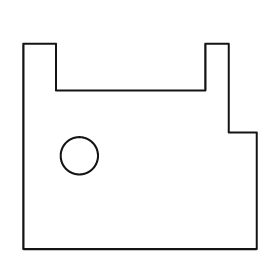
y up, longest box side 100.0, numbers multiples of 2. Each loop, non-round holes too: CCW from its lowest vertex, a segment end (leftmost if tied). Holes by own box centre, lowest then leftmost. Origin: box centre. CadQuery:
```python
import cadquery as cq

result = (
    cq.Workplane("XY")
    .moveTo(-50.0, -44.0)
    .lineTo(50.0, -44.0)
    .lineTo(50.0, 6.0)
    .lineTo(38.0, 6.0)
    .lineTo(38.0, 44.0)
    .lineTo(28.0, 44.0)
    .lineTo(28.0, 24.0)
    .lineTo(-36.0, 24.0)
    .lineTo(-36.0, 44.0)
    .lineTo(-50.0, 44.0)
    .close()
    .moveTo(-26.0, -4.0)
    .circle(8.0)
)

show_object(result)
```